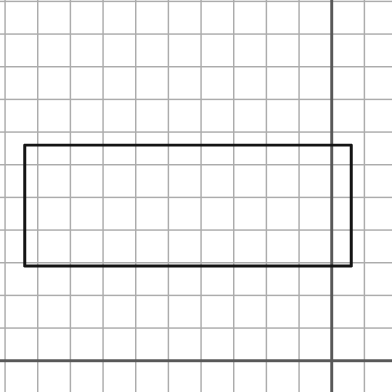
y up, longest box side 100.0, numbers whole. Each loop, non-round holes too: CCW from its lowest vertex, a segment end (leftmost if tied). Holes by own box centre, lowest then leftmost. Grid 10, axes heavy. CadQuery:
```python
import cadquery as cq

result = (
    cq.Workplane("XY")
    .moveTo(-94.0, 29.0)
    .lineTo(6.0, 29.0)
    .lineTo(6.0, 66.0)
    .lineTo(-94.0, 66.0)
    .close()
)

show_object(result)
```